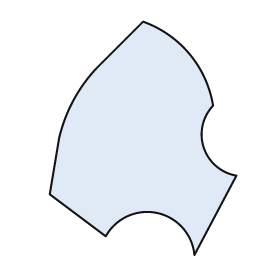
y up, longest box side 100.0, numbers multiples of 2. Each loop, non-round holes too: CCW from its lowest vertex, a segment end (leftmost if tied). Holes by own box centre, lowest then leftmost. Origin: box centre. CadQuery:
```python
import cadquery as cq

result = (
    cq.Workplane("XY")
    .moveTo(22.0, -50.0)
    .lineTo(40.0, -16.0)
    .threePointArc((26.0, -4.0), (30.0, 14.0))
    .threePointArc((20.0, 36.0), (0.0, 50.0))
    .lineTo(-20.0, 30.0)
    .threePointArc((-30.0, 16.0), (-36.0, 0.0))
    .lineTo(-40.0, -24.0)
    .lineTo(-16.0, -42.0)
    .threePointArc((6.0, -32.0), (22.0, -50.0))
    .close()
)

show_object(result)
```